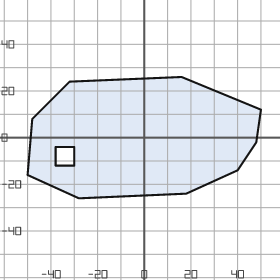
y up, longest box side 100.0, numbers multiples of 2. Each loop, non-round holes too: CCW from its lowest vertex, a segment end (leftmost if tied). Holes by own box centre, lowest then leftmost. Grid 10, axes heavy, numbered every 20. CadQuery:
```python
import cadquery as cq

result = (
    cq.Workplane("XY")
    .moveTo(-28.0, -26.0)
    .lineTo(18.0, -24.0)
    .lineTo(40.0, -14.0)
    .lineTo(48.0, -2.0)
    .lineTo(50.0, 12.0)
    .lineTo(16.0, 26.0)
    .lineTo(-32.0, 24.0)
    .lineTo(-48.0, 8.0)
    .lineTo(-50.0, -16.0)
    .close()
    .moveTo(-38.0, -12.0)
    .lineTo(-30.0, -12.0)
    .lineTo(-30.0, -4.0)
    .lineTo(-38.0, -4.0)
    .close()
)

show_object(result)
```